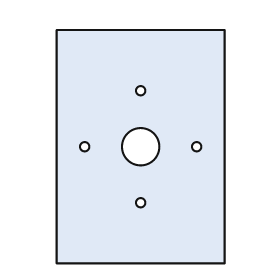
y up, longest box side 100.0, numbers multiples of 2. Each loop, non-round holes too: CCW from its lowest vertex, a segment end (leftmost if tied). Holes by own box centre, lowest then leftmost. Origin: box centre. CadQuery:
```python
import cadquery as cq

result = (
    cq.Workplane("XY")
    .moveTo(-36.0, -50.0)
    .lineTo(36.0, -50.0)
    .lineTo(36.0, 50.0)
    .lineTo(-36.0, 50.0)
    .close()
    .moveTo(0.0, -24.0)
    .circle(2.0)
    .moveTo(-24.0, 0.0)
    .circle(2.0)
    .moveTo(0.0, 0.0)
    .circle(8.0)
    .moveTo(24.0, 0.0)
    .circle(2.0)
    .moveTo(0.0, 24.0)
    .circle(2.0)
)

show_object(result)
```